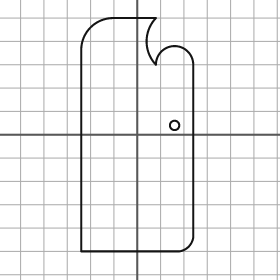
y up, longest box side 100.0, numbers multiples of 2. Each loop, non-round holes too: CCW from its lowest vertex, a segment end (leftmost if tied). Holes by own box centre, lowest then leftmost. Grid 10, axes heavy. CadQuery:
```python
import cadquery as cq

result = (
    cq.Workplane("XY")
    .moveTo(-24.0, -50.0)
    .lineTo(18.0, -50.0)
    .threePointArc((22.0, -48.0), (24.0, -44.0))
    .lineTo(24.0, 30.0)
    .threePointArc((16.0, 38.0), (8.0, 30.0))
    .threePointArc((4.0, 40.0), (8.0, 50.0))
    .lineTo(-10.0, 50.0)
    .threePointArc((-20.0, 46.0), (-24.0, 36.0))
    .close()
    .moveTo(16.0, 4.0)
    .circle(2.0)
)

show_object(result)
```